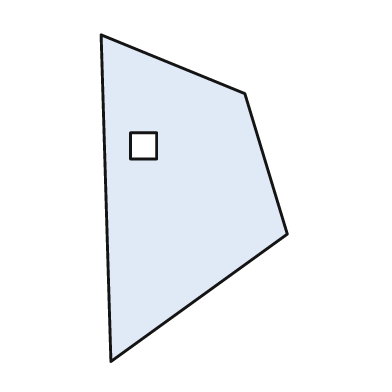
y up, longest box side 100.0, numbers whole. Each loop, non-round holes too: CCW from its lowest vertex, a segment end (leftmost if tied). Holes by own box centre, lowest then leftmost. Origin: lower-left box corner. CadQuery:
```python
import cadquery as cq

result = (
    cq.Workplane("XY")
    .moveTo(3.0, 0.0)
    .lineTo(57.0, 39.0)
    .lineTo(44.0, 82.0)
    .lineTo(0.0, 100.0)
    .close()
    .moveTo(9.0, 62.0)
    .lineTo(17.0, 62.0)
    .lineTo(17.0, 70.0)
    .lineTo(9.0, 70.0)
    .close()
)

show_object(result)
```